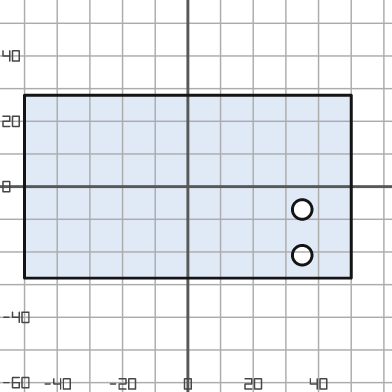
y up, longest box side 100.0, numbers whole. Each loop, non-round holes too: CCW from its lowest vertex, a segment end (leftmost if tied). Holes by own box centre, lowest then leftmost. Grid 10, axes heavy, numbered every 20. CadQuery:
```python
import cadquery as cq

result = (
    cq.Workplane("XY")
    .moveTo(-50.0, -28.0)
    .lineTo(50.0, -28.0)
    .lineTo(50.0, 28.0)
    .lineTo(-50.0, 28.0)
    .close()
    .moveTo(35.0, -21.0)
    .circle(3.0)
    .moveTo(35.0, -7.0)
    .circle(3.0)
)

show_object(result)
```